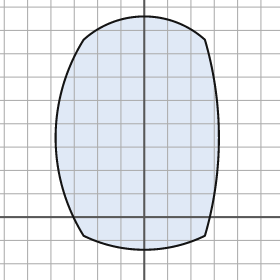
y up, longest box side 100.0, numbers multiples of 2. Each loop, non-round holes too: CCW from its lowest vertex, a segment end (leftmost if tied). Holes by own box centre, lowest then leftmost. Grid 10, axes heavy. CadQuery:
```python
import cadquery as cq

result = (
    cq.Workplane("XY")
    .moveTo(-26.0, -8.0)
    .threePointArc((0.0, -14.0), (26.0, -8.0))
    .threePointArc((32.0, 34.0), (26.0, 76.0))
    .threePointArc((0.0, 86.0), (-26.0, 76.0))
    .threePointArc((-38.0, 34.0), (-26.0, -8.0))
    .close()
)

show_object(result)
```